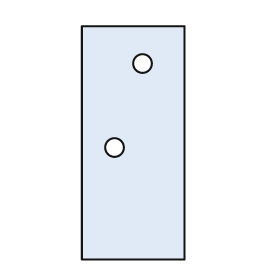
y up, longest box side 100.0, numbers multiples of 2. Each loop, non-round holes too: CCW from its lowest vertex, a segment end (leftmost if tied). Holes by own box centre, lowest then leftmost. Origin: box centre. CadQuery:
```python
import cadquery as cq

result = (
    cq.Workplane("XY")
    .moveTo(-22.0, -50.0)
    .lineTo(22.0, -50.0)
    .lineTo(22.0, 50.0)
    .lineTo(-22.0, 50.0)
    .close()
    .moveTo(-8.0, -2.0)
    .circle(4.0)
    .moveTo(4.0, 34.0)
    .circle(4.0)
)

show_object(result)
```